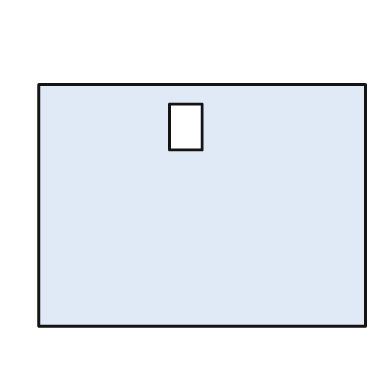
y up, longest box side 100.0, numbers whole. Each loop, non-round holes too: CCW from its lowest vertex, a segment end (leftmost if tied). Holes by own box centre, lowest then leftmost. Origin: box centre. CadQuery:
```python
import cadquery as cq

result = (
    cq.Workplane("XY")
    .moveTo(-50.0, -37.0)
    .lineTo(50.0, -37.0)
    .lineTo(50.0, 37.0)
    .lineTo(-50.0, 37.0)
    .close()
    .moveTo(-10.0, 17.0)
    .lineTo(0.0, 17.0)
    .lineTo(0.0, 31.0)
    .lineTo(-10.0, 31.0)
    .close()
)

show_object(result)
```